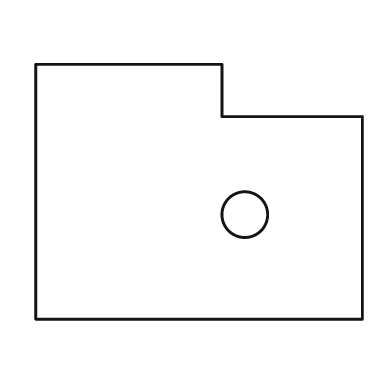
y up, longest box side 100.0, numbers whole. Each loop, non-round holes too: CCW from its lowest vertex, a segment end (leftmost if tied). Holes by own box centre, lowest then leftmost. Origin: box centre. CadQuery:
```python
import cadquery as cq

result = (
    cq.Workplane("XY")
    .moveTo(-50.0, -39.0)
    .lineTo(50.0, -39.0)
    .lineTo(50.0, 23.0)
    .lineTo(7.0, 23.0)
    .lineTo(7.0, 39.0)
    .lineTo(-50.0, 39.0)
    .close()
    .moveTo(14.0, -7.0)
    .circle(7.0)
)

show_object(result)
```